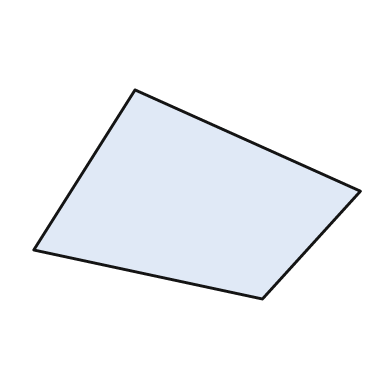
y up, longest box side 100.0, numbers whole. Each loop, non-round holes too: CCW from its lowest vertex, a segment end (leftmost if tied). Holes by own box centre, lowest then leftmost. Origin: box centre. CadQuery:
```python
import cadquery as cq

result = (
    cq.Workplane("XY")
    .moveTo(20.0, -32.0)
    .lineTo(50.0, 1.0)
    .lineTo(-19.0, 32.0)
    .lineTo(-50.0, -17.0)
    .close()
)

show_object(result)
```